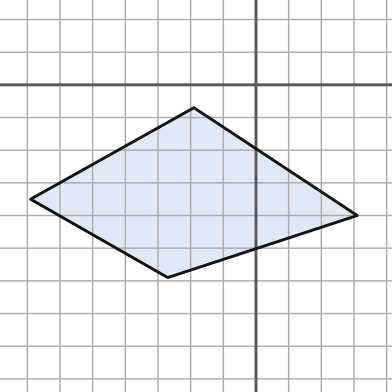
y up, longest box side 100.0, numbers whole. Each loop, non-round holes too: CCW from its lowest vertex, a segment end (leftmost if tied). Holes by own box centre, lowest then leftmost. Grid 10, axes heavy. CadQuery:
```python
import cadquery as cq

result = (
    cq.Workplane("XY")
    .moveTo(-27.0, -59.0)
    .lineTo(31.0, -40.0)
    .lineTo(-19.0, -7.0)
    .lineTo(-69.0, -35.0)
    .close()
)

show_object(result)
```